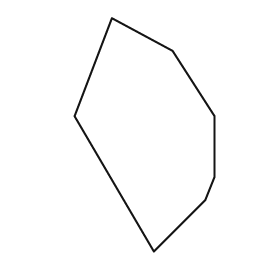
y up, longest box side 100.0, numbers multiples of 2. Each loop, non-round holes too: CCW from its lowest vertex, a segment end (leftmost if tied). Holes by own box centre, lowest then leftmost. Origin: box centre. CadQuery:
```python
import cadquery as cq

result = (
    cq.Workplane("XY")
    .moveTo(4.0, -50.0)
    .lineTo(26.0, -28.0)
    .lineTo(30.0, -18.0)
    .lineTo(30.0, 8.0)
    .lineTo(12.0, 36.0)
    .lineTo(-14.0, 50.0)
    .lineTo(-30.0, 8.0)
    .close()
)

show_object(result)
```